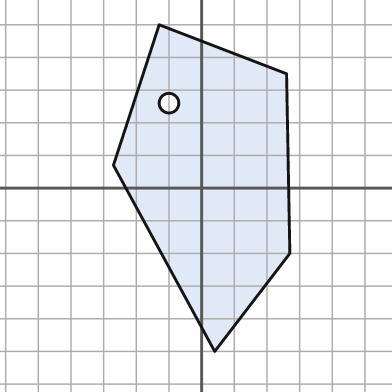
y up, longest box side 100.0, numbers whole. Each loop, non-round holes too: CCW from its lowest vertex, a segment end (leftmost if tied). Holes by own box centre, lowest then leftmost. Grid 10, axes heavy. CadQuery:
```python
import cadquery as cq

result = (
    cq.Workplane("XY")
    .moveTo(4.0, -50.0)
    .lineTo(27.0, -20.0)
    .lineTo(26.0, 35.0)
    .lineTo(-13.0, 50.0)
    .lineTo(-27.0, 7.0)
    .close()
    .moveTo(-10.0, 26.0)
    .circle(3.0)
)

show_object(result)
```